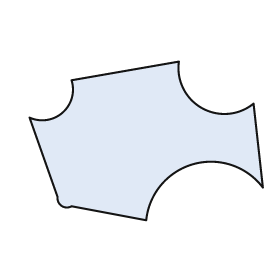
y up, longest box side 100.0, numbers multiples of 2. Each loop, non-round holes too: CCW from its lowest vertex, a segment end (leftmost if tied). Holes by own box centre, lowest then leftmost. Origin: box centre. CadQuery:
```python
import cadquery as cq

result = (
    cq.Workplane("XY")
    .moveTo(0.0, -34.0)
    .threePointArc((20.0, -10.0), (50.0, -20.0))
    .lineTo(46.0, 16.0)
    .threePointArc((24.0, 14.0), (14.0, 34.0))
    .lineTo(-32.0, 26.0)
    .threePointArc((-36.0, 12.0), (-50.0, 10.0))
    .lineTo(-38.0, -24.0)
    .threePointArc((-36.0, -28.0), (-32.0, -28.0))
    .close()
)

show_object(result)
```